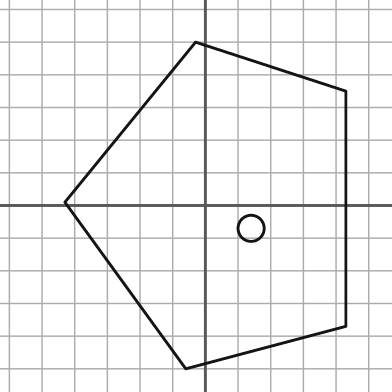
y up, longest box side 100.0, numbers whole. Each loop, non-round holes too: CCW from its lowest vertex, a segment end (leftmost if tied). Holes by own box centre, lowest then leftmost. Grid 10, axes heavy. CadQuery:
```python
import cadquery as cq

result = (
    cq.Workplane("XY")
    .moveTo(-6.0, -50.0)
    .lineTo(43.0, -37.0)
    .lineTo(43.0, 35.0)
    .lineTo(-3.0, 50.0)
    .lineTo(-43.0, 1.0)
    .close()
    .moveTo(14.0, -7.0)
    .circle(4.0)
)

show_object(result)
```